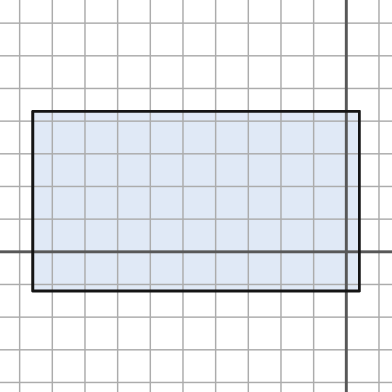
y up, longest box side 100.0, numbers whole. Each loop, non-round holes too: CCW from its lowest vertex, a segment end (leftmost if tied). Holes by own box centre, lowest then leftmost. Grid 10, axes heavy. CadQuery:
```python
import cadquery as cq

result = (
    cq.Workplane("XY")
    .moveTo(-96.0, -12.0)
    .lineTo(4.0, -12.0)
    .lineTo(4.0, 43.0)
    .lineTo(-96.0, 43.0)
    .close()
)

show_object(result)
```